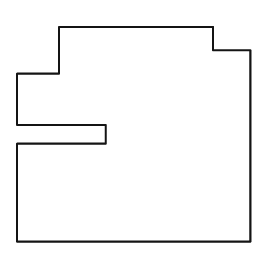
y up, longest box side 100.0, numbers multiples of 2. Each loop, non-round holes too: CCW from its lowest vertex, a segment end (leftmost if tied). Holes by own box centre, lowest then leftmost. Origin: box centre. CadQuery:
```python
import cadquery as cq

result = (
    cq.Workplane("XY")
    .moveTo(-50.0, -46.0)
    .lineTo(50.0, -46.0)
    .lineTo(50.0, 36.0)
    .lineTo(34.0, 36.0)
    .lineTo(34.0, 46.0)
    .lineTo(-32.0, 46.0)
    .lineTo(-32.0, 26.0)
    .lineTo(-50.0, 26.0)
    .lineTo(-50.0, 4.0)
    .lineTo(-12.0, 4.0)
    .lineTo(-12.0, -4.0)
    .lineTo(-50.0, -4.0)
    .close()
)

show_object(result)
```